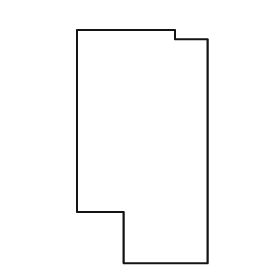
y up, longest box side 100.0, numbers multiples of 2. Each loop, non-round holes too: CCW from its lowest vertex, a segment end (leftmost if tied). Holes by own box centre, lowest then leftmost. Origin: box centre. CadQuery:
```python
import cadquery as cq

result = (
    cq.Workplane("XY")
    .moveTo(-8.0, -50.0)
    .lineTo(28.0, -50.0)
    .lineTo(28.0, 46.0)
    .lineTo(14.0, 46.0)
    .lineTo(14.0, 50.0)
    .lineTo(-28.0, 50.0)
    .lineTo(-28.0, -28.0)
    .lineTo(-8.0, -28.0)
    .close()
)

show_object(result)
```